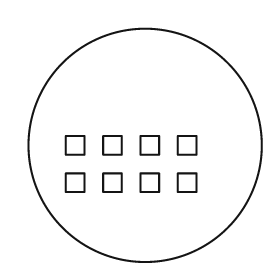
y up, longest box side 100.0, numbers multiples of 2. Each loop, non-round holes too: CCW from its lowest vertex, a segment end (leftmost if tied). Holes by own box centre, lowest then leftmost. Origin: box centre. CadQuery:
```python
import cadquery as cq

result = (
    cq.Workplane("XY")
    .moveTo(0.0, 0.0)
    .circle(50.0)
    .moveTo(-34.0, -20.0)
    .lineTo(-26.0, -20.0)
    .lineTo(-26.0, -12.0)
    .lineTo(-34.0, -12.0)
    .close()
    .moveTo(-18.0, -20.0)
    .lineTo(-10.0, -20.0)
    .lineTo(-10.0, -12.0)
    .lineTo(-18.0, -12.0)
    .close()
    .moveTo(-2.0, -20.0)
    .lineTo(6.0, -20.0)
    .lineTo(6.0, -12.0)
    .lineTo(-2.0, -12.0)
    .close()
    .moveTo(14.0, -20.0)
    .lineTo(22.0, -20.0)
    .lineTo(22.0, -12.0)
    .lineTo(14.0, -12.0)
    .close()
    .moveTo(-34.0, -4.0)
    .lineTo(-26.0, -4.0)
    .lineTo(-26.0, 4.0)
    .lineTo(-34.0, 4.0)
    .close()
    .moveTo(-18.0, -4.0)
    .lineTo(-10.0, -4.0)
    .lineTo(-10.0, 4.0)
    .lineTo(-18.0, 4.0)
    .close()
    .moveTo(-2.0, -4.0)
    .lineTo(6.0, -4.0)
    .lineTo(6.0, 4.0)
    .lineTo(-2.0, 4.0)
    .close()
    .moveTo(14.0, -4.0)
    .lineTo(22.0, -4.0)
    .lineTo(22.0, 4.0)
    .lineTo(14.0, 4.0)
    .close()
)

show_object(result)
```